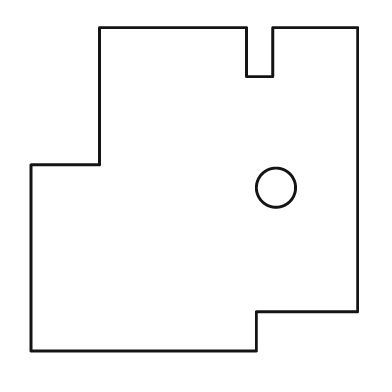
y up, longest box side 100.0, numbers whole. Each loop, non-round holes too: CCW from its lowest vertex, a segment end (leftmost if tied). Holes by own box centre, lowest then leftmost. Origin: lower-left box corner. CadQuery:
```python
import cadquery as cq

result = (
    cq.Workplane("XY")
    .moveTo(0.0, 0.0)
    .lineTo(69.0, 0.0)
    .lineTo(69.0, 12.0)
    .lineTo(100.0, 12.0)
    .lineTo(100.0, 99.0)
    .lineTo(74.0, 99.0)
    .lineTo(74.0, 84.0)
    .lineTo(66.0, 84.0)
    .lineTo(66.0, 99.0)
    .lineTo(21.0, 99.0)
    .lineTo(21.0, 57.0)
    .lineTo(0.0, 57.0)
    .close()
    .moveTo(75.0, 50.0)
    .circle(6.0)
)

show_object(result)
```